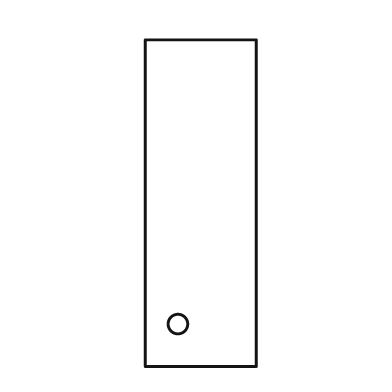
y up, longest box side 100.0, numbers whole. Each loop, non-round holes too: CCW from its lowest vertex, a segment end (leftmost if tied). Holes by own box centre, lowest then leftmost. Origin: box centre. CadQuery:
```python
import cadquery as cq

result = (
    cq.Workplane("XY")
    .moveTo(-17.0, -50.0)
    .lineTo(17.0, -50.0)
    .lineTo(17.0, 50.0)
    .lineTo(-17.0, 50.0)
    .close()
    .moveTo(-7.0, -37.0)
    .circle(3.0)
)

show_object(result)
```